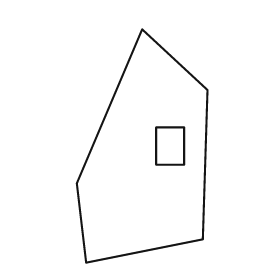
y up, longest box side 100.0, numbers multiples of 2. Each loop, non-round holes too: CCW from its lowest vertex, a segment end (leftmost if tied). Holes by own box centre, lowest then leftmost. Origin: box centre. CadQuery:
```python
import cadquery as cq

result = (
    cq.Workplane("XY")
    .moveTo(-24.0, -50.0)
    .lineTo(26.0, -40.0)
    .lineTo(28.0, 24.0)
    .lineTo(0.0, 50.0)
    .lineTo(-28.0, -16.0)
    .close()
    .moveTo(6.0, -8.0)
    .lineTo(18.0, -8.0)
    .lineTo(18.0, 8.0)
    .lineTo(6.0, 8.0)
    .close()
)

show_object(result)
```